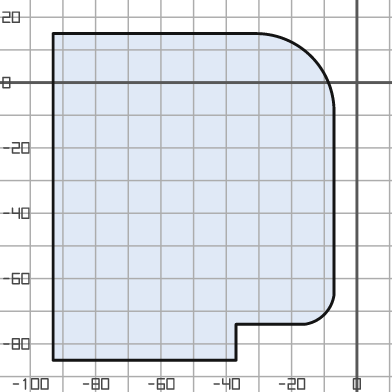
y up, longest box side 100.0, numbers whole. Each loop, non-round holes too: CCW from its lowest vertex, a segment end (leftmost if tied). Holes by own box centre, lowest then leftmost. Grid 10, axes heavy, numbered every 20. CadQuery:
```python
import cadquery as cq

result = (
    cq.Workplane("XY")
    .moveTo(-93.0, -85.0)
    .lineTo(-37.0, -85.0)
    .lineTo(-37.0, -74.0)
    .lineTo(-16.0, -74.0)
    .threePointArc((-10.0, -71.0), (-7.0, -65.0))
    .lineTo(-7.0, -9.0)
    .threePointArc((-14.0, 8.0), (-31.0, 15.0))
    .lineTo(-93.0, 15.0)
    .close()
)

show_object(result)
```